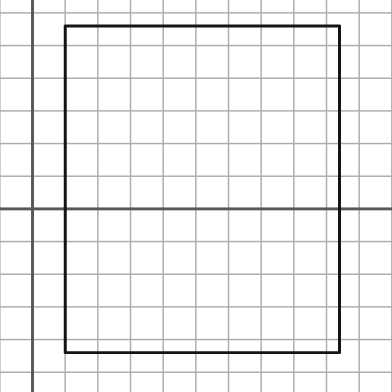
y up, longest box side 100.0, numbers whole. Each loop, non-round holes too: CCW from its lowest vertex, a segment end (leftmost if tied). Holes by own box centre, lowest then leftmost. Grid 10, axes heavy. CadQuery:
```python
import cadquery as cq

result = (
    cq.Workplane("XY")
    .moveTo(10.0, -44.0)
    .lineTo(94.0, -44.0)
    .lineTo(94.0, 56.0)
    .lineTo(10.0, 56.0)
    .close()
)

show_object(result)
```